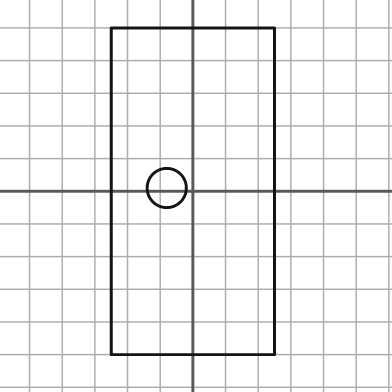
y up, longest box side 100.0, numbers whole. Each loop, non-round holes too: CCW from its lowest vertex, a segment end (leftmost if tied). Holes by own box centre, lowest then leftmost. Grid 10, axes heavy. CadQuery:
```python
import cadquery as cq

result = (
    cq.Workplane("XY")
    .moveTo(-25.0, -50.0)
    .lineTo(25.0, -50.0)
    .lineTo(25.0, 50.0)
    .lineTo(-25.0, 50.0)
    .close()
    .moveTo(-8.0, 1.0)
    .circle(6.0)
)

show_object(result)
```